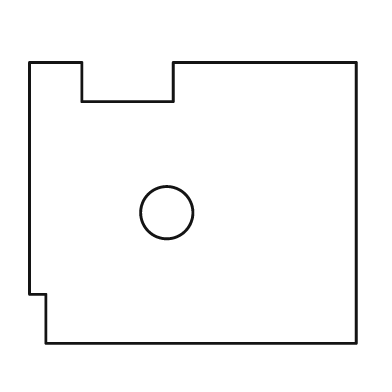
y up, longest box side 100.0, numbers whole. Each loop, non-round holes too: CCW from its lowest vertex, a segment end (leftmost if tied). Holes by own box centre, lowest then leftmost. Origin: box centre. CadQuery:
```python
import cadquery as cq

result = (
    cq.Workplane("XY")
    .moveTo(-45.0, -43.0)
    .lineTo(50.0, -43.0)
    .lineTo(50.0, 43.0)
    .lineTo(-6.0, 43.0)
    .lineTo(-6.0, 31.0)
    .lineTo(-34.0, 31.0)
    .lineTo(-34.0, 43.0)
    .lineTo(-50.0, 43.0)
    .lineTo(-50.0, -28.0)
    .lineTo(-45.0, -28.0)
    .close()
    .moveTo(-8.0, -3.0)
    .circle(8.0)
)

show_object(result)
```